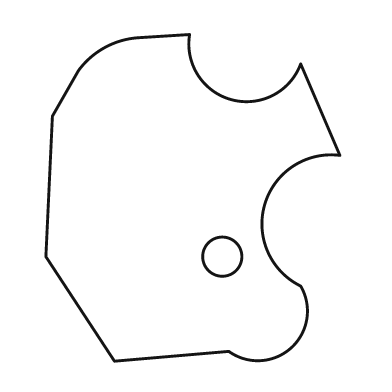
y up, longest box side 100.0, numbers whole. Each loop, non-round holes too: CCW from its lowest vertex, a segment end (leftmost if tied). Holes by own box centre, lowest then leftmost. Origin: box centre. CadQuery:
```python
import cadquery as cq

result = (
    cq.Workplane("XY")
    .moveTo(-24.0, -50.0)
    .lineTo(11.0, -47.0)
    .threePointArc((30.0, -46.0), (33.0, -27.0))
    .threePointArc((22.0, -2.0), (45.0, 13.0))
    .lineTo(33.0, 41.0)
    .threePointArc((12.0, 30.0), (-1.0, 50.0))
    .lineTo(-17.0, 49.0)
    .threePointArc((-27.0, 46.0), (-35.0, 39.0))
    .lineTo(-43.0, 25.0)
    .lineTo(-45.0, -18.0)
    .close()
    .moveTo(9.0, -18.0)
    .circle(6.0)
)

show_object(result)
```